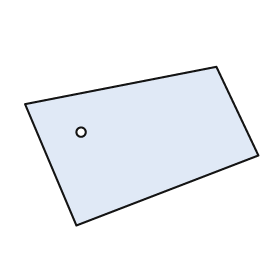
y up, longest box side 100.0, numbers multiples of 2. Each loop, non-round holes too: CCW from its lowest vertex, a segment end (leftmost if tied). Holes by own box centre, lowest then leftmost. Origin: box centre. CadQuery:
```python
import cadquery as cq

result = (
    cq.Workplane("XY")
    .moveTo(-28.0, -34.0)
    .lineTo(50.0, -4.0)
    .lineTo(32.0, 34.0)
    .lineTo(-50.0, 18.0)
    .close()
    .moveTo(-26.0, 6.0)
    .circle(2.0)
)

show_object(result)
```